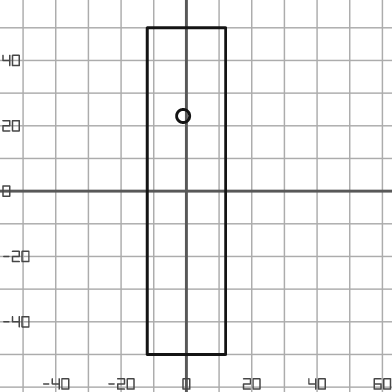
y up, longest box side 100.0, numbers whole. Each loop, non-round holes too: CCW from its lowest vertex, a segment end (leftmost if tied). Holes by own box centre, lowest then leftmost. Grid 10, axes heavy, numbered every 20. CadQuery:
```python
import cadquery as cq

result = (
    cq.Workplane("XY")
    .moveTo(-12.0, -50.0)
    .lineTo(12.0, -50.0)
    .lineTo(12.0, 50.0)
    .lineTo(-12.0, 50.0)
    .close()
    .moveTo(-1.0, 23.0)
    .circle(2.0)
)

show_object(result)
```